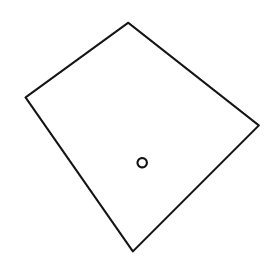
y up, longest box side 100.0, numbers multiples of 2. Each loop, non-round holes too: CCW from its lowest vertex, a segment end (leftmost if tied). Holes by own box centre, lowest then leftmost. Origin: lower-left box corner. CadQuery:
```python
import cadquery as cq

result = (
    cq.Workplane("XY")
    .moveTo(46.0, 0.0)
    .lineTo(100.0, 54.0)
    .lineTo(44.0, 98.0)
    .lineTo(0.0, 66.0)
    .close()
    .moveTo(50.0, 38.0)
    .circle(2.0)
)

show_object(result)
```